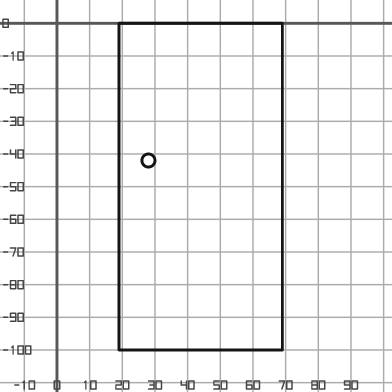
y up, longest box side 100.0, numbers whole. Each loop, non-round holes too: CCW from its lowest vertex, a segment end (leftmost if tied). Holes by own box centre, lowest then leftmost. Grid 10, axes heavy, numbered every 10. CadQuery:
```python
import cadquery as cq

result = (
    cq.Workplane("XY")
    .moveTo(19.0, -100.0)
    .lineTo(69.0, -100.0)
    .lineTo(69.0, 0.0)
    .lineTo(19.0, 0.0)
    .close()
    .moveTo(28.0, -42.0)
    .circle(2.0)
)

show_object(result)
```